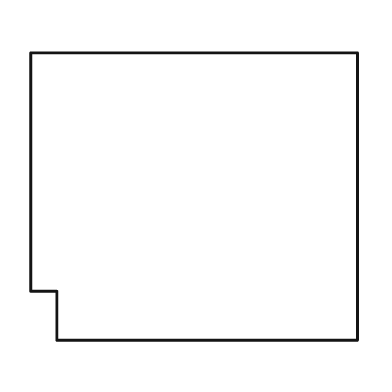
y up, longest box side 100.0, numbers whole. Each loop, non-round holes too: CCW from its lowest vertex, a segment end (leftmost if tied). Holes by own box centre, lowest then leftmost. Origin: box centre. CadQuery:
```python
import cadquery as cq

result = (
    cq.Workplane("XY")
    .moveTo(-42.0, -44.0)
    .lineTo(50.0, -44.0)
    .lineTo(50.0, 44.0)
    .lineTo(-50.0, 44.0)
    .lineTo(-50.0, -29.0)
    .lineTo(-42.0, -29.0)
    .close()
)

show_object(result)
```